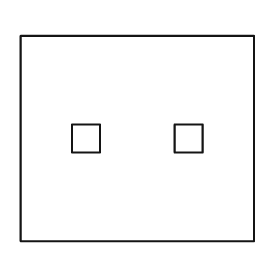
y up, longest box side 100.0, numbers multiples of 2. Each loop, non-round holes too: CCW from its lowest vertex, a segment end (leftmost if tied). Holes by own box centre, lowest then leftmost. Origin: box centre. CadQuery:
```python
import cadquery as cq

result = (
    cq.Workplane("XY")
    .moveTo(-50.0, -44.0)
    .lineTo(50.0, -44.0)
    .lineTo(50.0, 44.0)
    .lineTo(-50.0, 44.0)
    .close()
    .moveTo(-28.0, -6.0)
    .lineTo(-16.0, -6.0)
    .lineTo(-16.0, 6.0)
    .lineTo(-28.0, 6.0)
    .close()
    .moveTo(16.0, -6.0)
    .lineTo(28.0, -6.0)
    .lineTo(28.0, 6.0)
    .lineTo(16.0, 6.0)
    .close()
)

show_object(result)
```